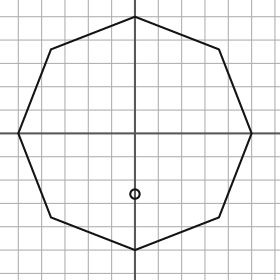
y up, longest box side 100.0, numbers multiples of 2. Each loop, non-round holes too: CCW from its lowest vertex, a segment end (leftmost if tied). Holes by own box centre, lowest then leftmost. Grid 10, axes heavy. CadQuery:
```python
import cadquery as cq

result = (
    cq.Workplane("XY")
    .moveTo(0.0, -50.0)
    .lineTo(36.0, -36.0)
    .lineTo(50.0, 0.0)
    .lineTo(36.0, 36.0)
    .lineTo(0.0, 50.0)
    .lineTo(-36.0, 36.0)
    .lineTo(-50.0, 0.0)
    .lineTo(-36.0, -36.0)
    .close()
    .moveTo(0.0, -26.0)
    .circle(2.0)
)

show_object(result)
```